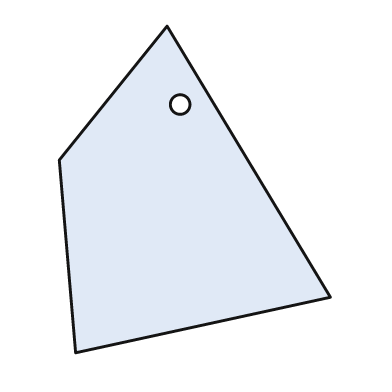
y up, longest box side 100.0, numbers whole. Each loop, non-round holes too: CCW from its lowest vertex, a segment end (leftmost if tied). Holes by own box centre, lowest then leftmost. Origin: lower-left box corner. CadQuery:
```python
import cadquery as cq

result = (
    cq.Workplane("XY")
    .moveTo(5.0, 0.0)
    .lineTo(83.0, 17.0)
    .lineTo(33.0, 100.0)
    .lineTo(0.0, 59.0)
    .close()
    .moveTo(37.0, 76.0)
    .circle(3.0)
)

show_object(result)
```